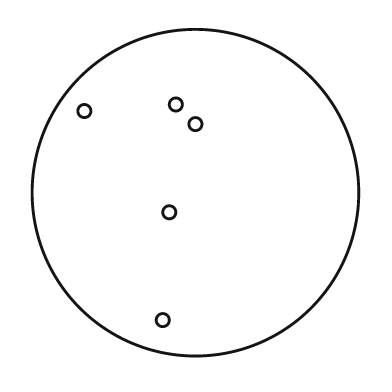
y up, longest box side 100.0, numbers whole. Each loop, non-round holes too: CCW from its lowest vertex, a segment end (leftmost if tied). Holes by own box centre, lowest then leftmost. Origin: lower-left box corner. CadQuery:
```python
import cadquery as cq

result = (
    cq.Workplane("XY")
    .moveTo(50.0, 50.0)
    .circle(50.0)
    .moveTo(40.0, 11.0)
    .circle(2.0)
    .moveTo(42.0, 44.0)
    .circle(2.0)
    .moveTo(50.0, 71.0)
    .circle(2.0)
    .moveTo(16.0, 75.0)
    .circle(2.0)
    .moveTo(44.0, 77.0)
    .circle(2.0)
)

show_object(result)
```